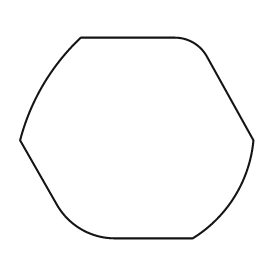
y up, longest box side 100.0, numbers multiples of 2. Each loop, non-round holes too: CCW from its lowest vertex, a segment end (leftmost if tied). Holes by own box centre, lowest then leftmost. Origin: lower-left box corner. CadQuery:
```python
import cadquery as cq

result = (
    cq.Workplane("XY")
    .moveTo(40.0, 0.0)
    .lineTo(74.0, 0.0)
    .threePointArc((92.0, 18.0), (100.0, 42.0))
    .lineTo(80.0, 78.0)
    .threePointArc((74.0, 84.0), (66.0, 86.0))
    .lineTo(26.0, 86.0)
    .threePointArc((10.0, 66.0), (0.0, 42.0))
    .lineTo(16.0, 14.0)
    .threePointArc((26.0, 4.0), (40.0, 0.0))
    .close()
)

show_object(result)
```